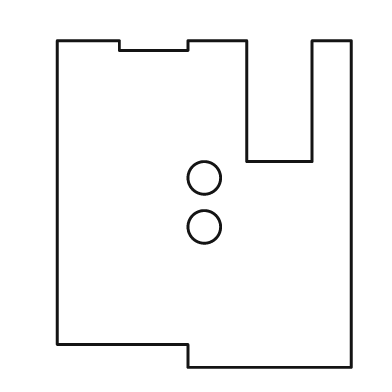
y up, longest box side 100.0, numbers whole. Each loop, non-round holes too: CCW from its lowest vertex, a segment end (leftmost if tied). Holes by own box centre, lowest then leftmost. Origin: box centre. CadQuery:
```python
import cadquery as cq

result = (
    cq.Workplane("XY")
    .moveTo(-5.0, -50.0)
    .lineTo(45.0, -50.0)
    .lineTo(45.0, 50.0)
    .lineTo(33.0, 50.0)
    .lineTo(33.0, 13.0)
    .lineTo(13.0, 13.0)
    .lineTo(13.0, 50.0)
    .lineTo(-5.0, 50.0)
    .lineTo(-5.0, 47.0)
    .lineTo(-26.0, 47.0)
    .lineTo(-26.0, 50.0)
    .lineTo(-45.0, 50.0)
    .lineTo(-45.0, -43.0)
    .lineTo(-5.0, -43.0)
    .close()
    .moveTo(0.0, -7.0)
    .circle(5.0)
    .moveTo(0.0, 8.0)
    .circle(5.0)
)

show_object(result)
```